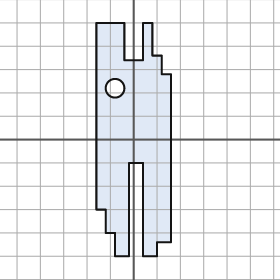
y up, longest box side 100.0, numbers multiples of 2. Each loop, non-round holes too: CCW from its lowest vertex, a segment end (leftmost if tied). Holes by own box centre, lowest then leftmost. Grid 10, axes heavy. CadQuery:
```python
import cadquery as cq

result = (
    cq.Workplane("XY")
    .moveTo(-8.0, -50.0)
    .lineTo(-2.0, -50.0)
    .lineTo(-2.0, -10.0)
    .lineTo(4.0, -10.0)
    .lineTo(4.0, -50.0)
    .lineTo(10.0, -50.0)
    .lineTo(10.0, -44.0)
    .lineTo(16.0, -44.0)
    .lineTo(16.0, 28.0)
    .lineTo(12.0, 28.0)
    .lineTo(12.0, 36.0)
    .lineTo(8.0, 36.0)
    .lineTo(8.0, 50.0)
    .lineTo(4.0, 50.0)
    .lineTo(4.0, 34.0)
    .lineTo(-4.0, 34.0)
    .lineTo(-4.0, 50.0)
    .lineTo(-16.0, 50.0)
    .lineTo(-16.0, -30.0)
    .lineTo(-12.0, -30.0)
    .lineTo(-12.0, -40.0)
    .lineTo(-8.0, -40.0)
    .close()
    .moveTo(-8.0, 22.0)
    .circle(4.0)
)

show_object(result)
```